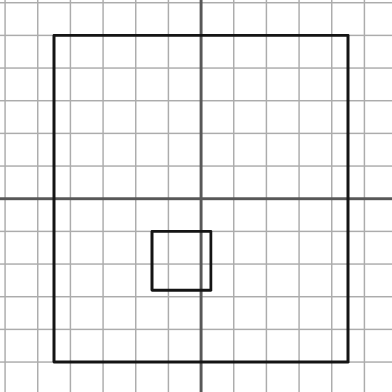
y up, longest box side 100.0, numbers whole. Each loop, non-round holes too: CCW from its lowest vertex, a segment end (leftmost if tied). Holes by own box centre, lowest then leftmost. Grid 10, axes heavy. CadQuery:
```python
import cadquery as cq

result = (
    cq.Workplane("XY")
    .moveTo(-45.0, -50.0)
    .lineTo(45.0, -50.0)
    .lineTo(45.0, 50.0)
    .lineTo(-45.0, 50.0)
    .close()
    .moveTo(-15.0, -28.0)
    .lineTo(3.0, -28.0)
    .lineTo(3.0, -10.0)
    .lineTo(-15.0, -10.0)
    .close()
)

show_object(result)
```